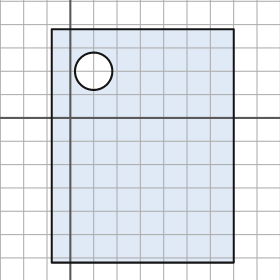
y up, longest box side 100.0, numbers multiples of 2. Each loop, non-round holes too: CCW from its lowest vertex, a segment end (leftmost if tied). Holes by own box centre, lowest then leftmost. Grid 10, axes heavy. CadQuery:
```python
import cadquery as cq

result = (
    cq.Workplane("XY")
    .moveTo(-8.0, -62.0)
    .lineTo(70.0, -62.0)
    .lineTo(70.0, 38.0)
    .lineTo(-8.0, 38.0)
    .close()
    .moveTo(10.0, 20.0)
    .circle(8.0)
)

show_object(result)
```